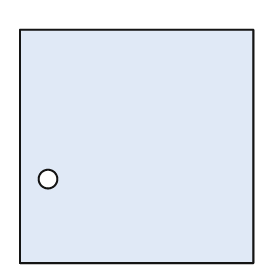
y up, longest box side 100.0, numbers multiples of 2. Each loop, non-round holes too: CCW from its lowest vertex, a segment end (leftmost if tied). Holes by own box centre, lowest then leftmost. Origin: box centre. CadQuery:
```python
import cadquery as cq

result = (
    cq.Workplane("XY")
    .moveTo(-50.0, -50.0)
    .lineTo(50.0, -50.0)
    .lineTo(50.0, 50.0)
    .lineTo(-50.0, 50.0)
    .close()
    .moveTo(-38.0, -14.0)
    .circle(4.0)
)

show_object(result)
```